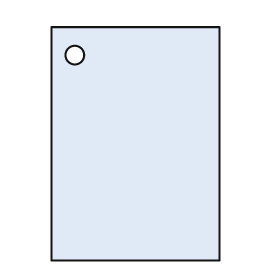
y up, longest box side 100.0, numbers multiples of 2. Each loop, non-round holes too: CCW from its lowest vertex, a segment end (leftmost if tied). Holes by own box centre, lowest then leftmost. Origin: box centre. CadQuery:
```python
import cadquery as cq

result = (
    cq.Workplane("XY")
    .moveTo(-36.0, -50.0)
    .lineTo(36.0, -50.0)
    .lineTo(36.0, 50.0)
    .lineTo(-36.0, 50.0)
    .close()
    .moveTo(-26.0, 38.0)
    .circle(4.0)
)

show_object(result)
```